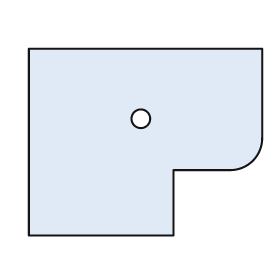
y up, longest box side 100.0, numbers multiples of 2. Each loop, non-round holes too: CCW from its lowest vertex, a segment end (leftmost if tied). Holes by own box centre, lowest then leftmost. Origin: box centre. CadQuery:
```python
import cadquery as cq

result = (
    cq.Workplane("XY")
    .moveTo(-50.0, -40.0)
    .lineTo(12.0, -40.0)
    .lineTo(12.0, -12.0)
    .lineTo(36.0, -12.0)
    .threePointArc((46.0, -8.0), (50.0, 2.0))
    .lineTo(50.0, 40.0)
    .lineTo(-50.0, 40.0)
    .close()
    .moveTo(-2.0, 10.0)
    .circle(4.0)
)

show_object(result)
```